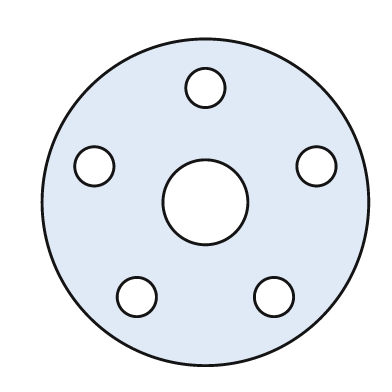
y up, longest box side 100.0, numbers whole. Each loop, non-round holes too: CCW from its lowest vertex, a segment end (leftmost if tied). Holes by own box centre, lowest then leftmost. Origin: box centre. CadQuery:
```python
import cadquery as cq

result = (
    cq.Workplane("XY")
    .moveTo(0.0, 0.0)
    .circle(50.0)
    .moveTo(-21.0, -29.0)
    .circle(6.0)
    .moveTo(21.0, -29.0)
    .circle(6.0)
    .moveTo(0.0, 0.0)
    .circle(13.0)
    .moveTo(-34.0, 11.0)
    .circle(6.0)
    .moveTo(34.0, 11.0)
    .circle(6.0)
    .moveTo(0.0, 35.0)
    .circle(6.0)
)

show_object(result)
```